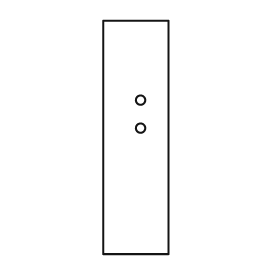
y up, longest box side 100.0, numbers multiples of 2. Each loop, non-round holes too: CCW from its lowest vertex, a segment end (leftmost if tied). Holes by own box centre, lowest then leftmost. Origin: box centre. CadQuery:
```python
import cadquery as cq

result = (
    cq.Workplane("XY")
    .moveTo(-14.0, -50.0)
    .lineTo(14.0, -50.0)
    .lineTo(14.0, 50.0)
    .lineTo(-14.0, 50.0)
    .close()
    .moveTo(2.0, 4.0)
    .circle(2.0)
    .moveTo(2.0, 16.0)
    .circle(2.0)
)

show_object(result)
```